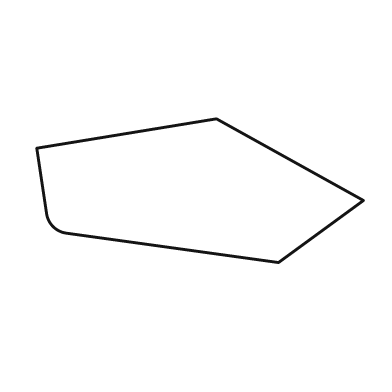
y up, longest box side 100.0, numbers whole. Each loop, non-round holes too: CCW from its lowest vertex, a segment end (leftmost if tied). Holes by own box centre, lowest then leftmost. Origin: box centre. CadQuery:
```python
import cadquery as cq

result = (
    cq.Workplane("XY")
    .moveTo(24.0, -22.0)
    .lineTo(50.0, -3.0)
    .lineTo(5.0, 22.0)
    .lineTo(-50.0, 13.0)
    .lineTo(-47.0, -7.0)
    .threePointArc((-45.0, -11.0), (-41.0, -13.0))
    .close()
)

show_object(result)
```